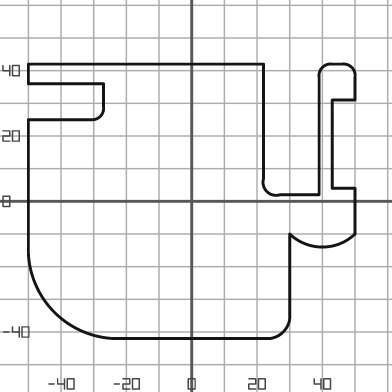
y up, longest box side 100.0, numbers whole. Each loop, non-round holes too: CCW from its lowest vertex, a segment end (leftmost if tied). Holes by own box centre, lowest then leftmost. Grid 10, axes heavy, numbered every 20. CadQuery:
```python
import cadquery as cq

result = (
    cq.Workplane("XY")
    .moveTo(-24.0, -42.0)
    .lineTo(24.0, -42.0)
    .threePointArc((28.0, -40.0), (30.0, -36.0))
    .lineTo(30.0, -10.0)
    .threePointArc((40.0, -14.0), (50.0, -10.0))
    .lineTo(50.0, 4.0)
    .lineTo(43.0, 4.0)
    .lineTo(43.0, 31.0)
    .lineTo(50.0, 31.0)
    .lineTo(50.0, 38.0)
    .threePointArc((49.0, 41.0), (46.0, 42.0))
    .lineTo(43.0, 42.0)
    .threePointArc((40.0, 41.0), (39.0, 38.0))
    .lineTo(39.0, 2.0)
    .lineTo(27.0, 2.0)
    .threePointArc((23.0, 3.0), (22.0, 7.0))
    .lineTo(22.0, 42.0)
    .lineTo(-50.0, 42.0)
    .lineTo(-50.0, 36.0)
    .lineTo(-27.0, 36.0)
    .lineTo(-27.0, 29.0)
    .threePointArc((-28.0, 26.0), (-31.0, 25.0))
    .lineTo(-50.0, 25.0)
    .lineTo(-50.0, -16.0)
    .threePointArc((-42.0, -34.0), (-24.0, -42.0))
    .close()
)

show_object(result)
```